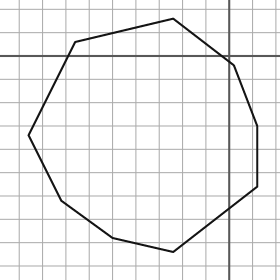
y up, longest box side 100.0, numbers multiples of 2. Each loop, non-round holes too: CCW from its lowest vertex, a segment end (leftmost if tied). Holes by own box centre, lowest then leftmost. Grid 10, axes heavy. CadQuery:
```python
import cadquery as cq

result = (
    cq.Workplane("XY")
    .moveTo(-24.0, -84.0)
    .lineTo(12.0, -56.0)
    .lineTo(12.0, -30.0)
    .lineTo(2.0, -4.0)
    .lineTo(-24.0, 16.0)
    .lineTo(-66.0, 6.0)
    .lineTo(-86.0, -34.0)
    .lineTo(-72.0, -62.0)
    .lineTo(-50.0, -78.0)
    .close()
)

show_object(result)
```